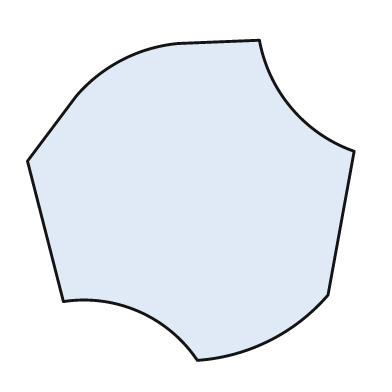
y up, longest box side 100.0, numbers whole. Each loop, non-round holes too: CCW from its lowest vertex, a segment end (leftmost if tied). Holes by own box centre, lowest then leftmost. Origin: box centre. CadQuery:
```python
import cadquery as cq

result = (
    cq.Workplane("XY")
    .moveTo(2.0, -49.0)
    .threePointArc((24.0, -43.0), (42.0, -29.0))
    .lineTo(50.0, 15.0)
    .threePointArc((31.0, 28.0), (21.0, 49.0))
    .lineTo(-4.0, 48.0)
    .threePointArc((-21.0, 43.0), (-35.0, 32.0))
    .lineTo(-50.0, 12.0)
    .lineTo(-39.0, -31.0)
    .threePointArc((-16.0, -34.0), (2.0, -49.0))
    .close()
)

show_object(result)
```